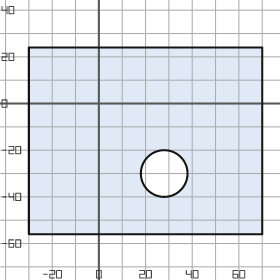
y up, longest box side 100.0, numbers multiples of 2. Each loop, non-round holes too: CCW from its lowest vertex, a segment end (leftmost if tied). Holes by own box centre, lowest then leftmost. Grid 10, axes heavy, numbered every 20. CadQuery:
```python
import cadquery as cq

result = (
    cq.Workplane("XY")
    .moveTo(-30.0, -56.0)
    .lineTo(70.0, -56.0)
    .lineTo(70.0, 24.0)
    .lineTo(-30.0, 24.0)
    .close()
    .moveTo(28.0, -30.0)
    .circle(10.0)
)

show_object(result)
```